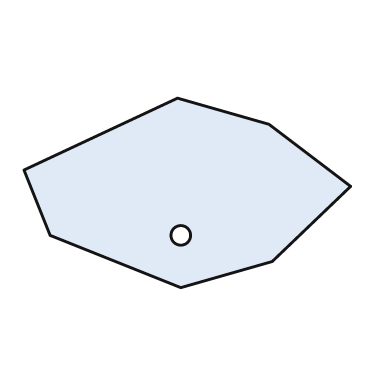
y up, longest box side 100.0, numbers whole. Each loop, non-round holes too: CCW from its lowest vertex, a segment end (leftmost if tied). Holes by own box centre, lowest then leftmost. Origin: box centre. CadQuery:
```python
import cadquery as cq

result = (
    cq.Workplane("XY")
    .moveTo(-2.0, -29.0)
    .lineTo(26.0, -21.0)
    .lineTo(50.0, 2.0)
    .lineTo(25.0, 21.0)
    .lineTo(-3.0, 29.0)
    .lineTo(-50.0, 7.0)
    .lineTo(-42.0, -13.0)
    .close()
    .moveTo(-2.0, -13.0)
    .circle(3.0)
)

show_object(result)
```